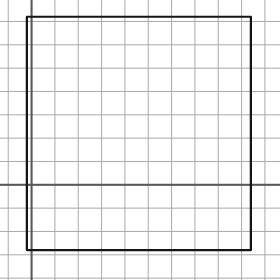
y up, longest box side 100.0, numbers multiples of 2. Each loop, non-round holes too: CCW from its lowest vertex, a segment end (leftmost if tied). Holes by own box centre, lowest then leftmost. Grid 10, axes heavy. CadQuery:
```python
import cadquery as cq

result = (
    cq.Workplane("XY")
    .moveTo(-2.0, -28.0)
    .lineTo(94.0, -28.0)
    .lineTo(94.0, 72.0)
    .lineTo(-2.0, 72.0)
    .close()
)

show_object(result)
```